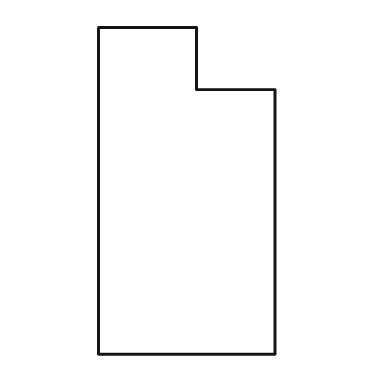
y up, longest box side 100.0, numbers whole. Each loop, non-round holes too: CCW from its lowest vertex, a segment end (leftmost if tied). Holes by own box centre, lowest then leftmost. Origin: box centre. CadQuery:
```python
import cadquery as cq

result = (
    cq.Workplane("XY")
    .moveTo(-27.0, -50.0)
    .lineTo(27.0, -50.0)
    .lineTo(27.0, 31.0)
    .lineTo(3.0, 31.0)
    .lineTo(3.0, 50.0)
    .lineTo(-27.0, 50.0)
    .close()
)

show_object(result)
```